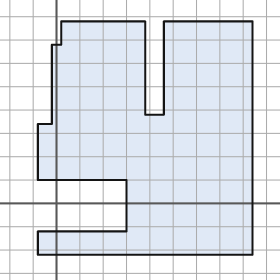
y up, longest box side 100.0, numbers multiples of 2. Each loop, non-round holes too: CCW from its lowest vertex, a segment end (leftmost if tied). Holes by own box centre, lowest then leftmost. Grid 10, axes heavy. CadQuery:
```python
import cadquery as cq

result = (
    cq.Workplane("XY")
    .moveTo(-8.0, -22.0)
    .lineTo(84.0, -22.0)
    .lineTo(84.0, 78.0)
    .lineTo(46.0, 78.0)
    .lineTo(46.0, 38.0)
    .lineTo(38.0, 38.0)
    .lineTo(38.0, 78.0)
    .lineTo(2.0, 78.0)
    .lineTo(2.0, 68.0)
    .lineTo(-2.0, 68.0)
    .lineTo(-2.0, 34.0)
    .lineTo(-8.0, 34.0)
    .lineTo(-8.0, 10.0)
    .lineTo(30.0, 10.0)
    .lineTo(30.0, -12.0)
    .lineTo(-8.0, -12.0)
    .close()
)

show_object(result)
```